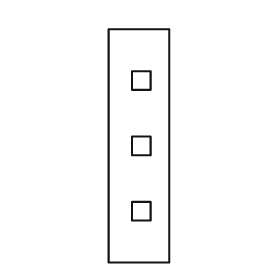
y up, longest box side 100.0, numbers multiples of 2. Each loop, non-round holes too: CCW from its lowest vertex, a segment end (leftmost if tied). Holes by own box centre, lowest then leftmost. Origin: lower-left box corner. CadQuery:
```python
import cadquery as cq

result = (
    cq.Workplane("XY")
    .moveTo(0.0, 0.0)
    .lineTo(26.0, 0.0)
    .lineTo(26.0, 100.0)
    .lineTo(0.0, 100.0)
    .close()
    .moveTo(10.0, 18.0)
    .lineTo(18.0, 18.0)
    .lineTo(18.0, 26.0)
    .lineTo(10.0, 26.0)
    .close()
    .moveTo(10.0, 46.0)
    .lineTo(18.0, 46.0)
    .lineTo(18.0, 54.0)
    .lineTo(10.0, 54.0)
    .close()
    .moveTo(10.0, 74.0)
    .lineTo(18.0, 74.0)
    .lineTo(18.0, 82.0)
    .lineTo(10.0, 82.0)
    .close()
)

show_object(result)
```